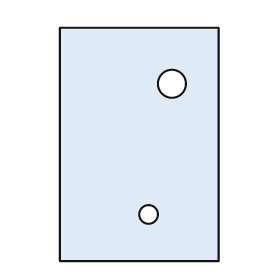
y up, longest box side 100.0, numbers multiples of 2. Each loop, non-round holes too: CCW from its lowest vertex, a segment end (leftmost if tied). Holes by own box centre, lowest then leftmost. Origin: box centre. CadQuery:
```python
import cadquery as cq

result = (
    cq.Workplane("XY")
    .moveTo(-34.0, -50.0)
    .lineTo(34.0, -50.0)
    .lineTo(34.0, 50.0)
    .lineTo(-34.0, 50.0)
    .close()
    .moveTo(4.0, -30.0)
    .circle(4.0)
    .moveTo(14.0, 26.0)
    .circle(6.0)
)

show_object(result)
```